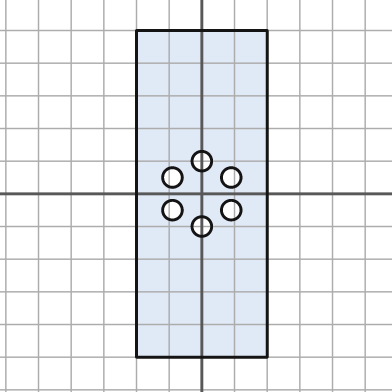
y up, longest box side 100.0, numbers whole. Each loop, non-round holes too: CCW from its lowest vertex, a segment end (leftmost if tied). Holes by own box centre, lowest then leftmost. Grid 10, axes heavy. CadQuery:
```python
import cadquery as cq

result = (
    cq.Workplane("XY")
    .moveTo(-20.0, -50.0)
    .lineTo(20.0, -50.0)
    .lineTo(20.0, 50.0)
    .lineTo(-20.0, 50.0)
    .close()
    .moveTo(0.0, -10.0)
    .circle(3.0)
    .moveTo(-9.0, -5.0)
    .circle(3.0)
    .moveTo(9.0, -5.0)
    .circle(3.0)
    .moveTo(-9.0, 5.0)
    .circle(3.0)
    .moveTo(9.0, 5.0)
    .circle(3.0)
    .moveTo(0.0, 10.0)
    .circle(3.0)
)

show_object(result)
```